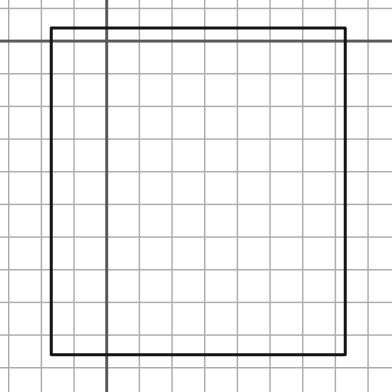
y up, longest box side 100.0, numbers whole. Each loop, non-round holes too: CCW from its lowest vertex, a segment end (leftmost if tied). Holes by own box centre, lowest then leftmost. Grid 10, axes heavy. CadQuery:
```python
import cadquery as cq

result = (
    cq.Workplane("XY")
    .moveTo(-17.0, -96.0)
    .lineTo(73.0, -96.0)
    .lineTo(73.0, 4.0)
    .lineTo(-17.0, 4.0)
    .close()
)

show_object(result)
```